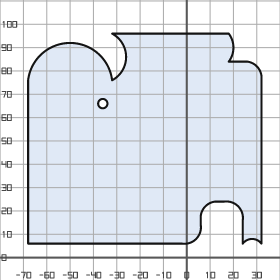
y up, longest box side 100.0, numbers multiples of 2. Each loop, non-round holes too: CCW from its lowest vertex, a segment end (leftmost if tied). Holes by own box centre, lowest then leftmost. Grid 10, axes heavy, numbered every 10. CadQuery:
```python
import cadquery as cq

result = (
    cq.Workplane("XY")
    .moveTo(-68.0, 6.0)
    .lineTo(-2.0, 6.0)
    .threePointArc((4.0, 8.0), (6.0, 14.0))
    .lineTo(6.0, 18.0)
    .threePointArc((8.0, 22.0), (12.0, 24.0))
    .lineTo(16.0, 24.0)
    .threePointArc((22.0, 22.0), (24.0, 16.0))
    .lineTo(24.0, 6.0)
    .threePointArc((28.0, 8.0), (32.0, 6.0))
    .lineTo(32.0, 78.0)
    .threePointArc((30.0, 82.0), (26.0, 84.0))
    .lineTo(18.0, 84.0)
    .threePointArc((20.0, 90.0), (18.0, 96.0))
    .lineTo(-32.0, 96.0)
    .threePointArc((-26.0, 86.0), (-32.0, 76.0))
    .threePointArc((-50.0, 92.0), (-68.0, 76.0))
    .close()
    .moveTo(-36.0, 66.0)
    .circle(2.0)
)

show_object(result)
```